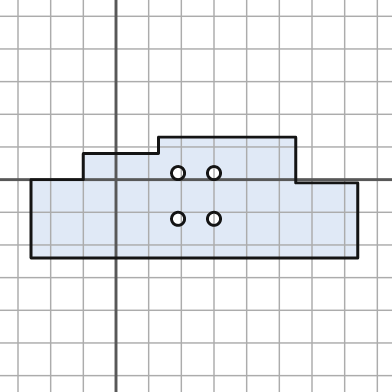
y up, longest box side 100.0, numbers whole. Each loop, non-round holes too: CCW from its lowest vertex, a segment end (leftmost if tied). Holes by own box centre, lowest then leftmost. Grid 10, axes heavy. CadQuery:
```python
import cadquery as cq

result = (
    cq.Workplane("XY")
    .moveTo(-26.0, -24.0)
    .lineTo(74.0, -24.0)
    .lineTo(74.0, -1.0)
    .lineTo(55.0, -1.0)
    .lineTo(55.0, 13.0)
    .lineTo(13.0, 13.0)
    .lineTo(13.0, 8.0)
    .lineTo(-10.0, 8.0)
    .lineTo(-10.0, 0.0)
    .lineTo(-26.0, 0.0)
    .close()
    .moveTo(19.0, -12.0)
    .circle(2.0)
    .moveTo(30.0, -12.0)
    .circle(2.0)
    .moveTo(19.0, 2.0)
    .circle(2.0)
    .moveTo(30.0, 2.0)
    .circle(2.0)
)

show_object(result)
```